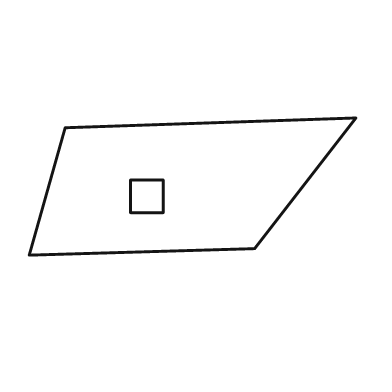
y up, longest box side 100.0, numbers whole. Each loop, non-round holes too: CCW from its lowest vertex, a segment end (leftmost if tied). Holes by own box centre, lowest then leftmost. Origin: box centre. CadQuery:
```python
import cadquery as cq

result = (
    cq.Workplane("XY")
    .moveTo(-50.0, -21.0)
    .lineTo(19.0, -19.0)
    .lineTo(50.0, 21.0)
    .lineTo(-39.0, 18.0)
    .close()
    .moveTo(-19.0, -8.0)
    .lineTo(-9.0, -8.0)
    .lineTo(-9.0, 2.0)
    .lineTo(-19.0, 2.0)
    .close()
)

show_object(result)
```